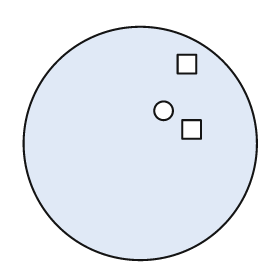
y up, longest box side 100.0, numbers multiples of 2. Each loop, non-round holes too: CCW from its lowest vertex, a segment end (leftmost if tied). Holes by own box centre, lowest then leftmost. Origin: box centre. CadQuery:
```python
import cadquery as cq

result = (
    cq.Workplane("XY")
    .moveTo(0.0, 0.0)
    .circle(50.0)
    .moveTo(18.0, 2.0)
    .lineTo(26.0, 2.0)
    .lineTo(26.0, 10.0)
    .lineTo(18.0, 10.0)
    .close()
    .moveTo(10.0, 14.0)
    .circle(4.0)
    .moveTo(16.0, 30.0)
    .lineTo(24.0, 30.0)
    .lineTo(24.0, 38.0)
    .lineTo(16.0, 38.0)
    .close()
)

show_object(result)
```